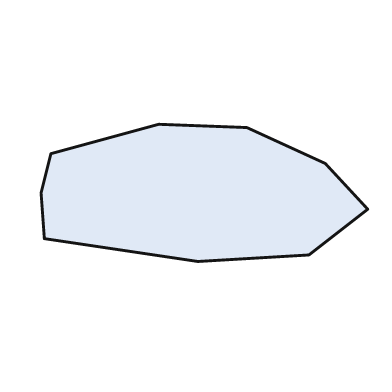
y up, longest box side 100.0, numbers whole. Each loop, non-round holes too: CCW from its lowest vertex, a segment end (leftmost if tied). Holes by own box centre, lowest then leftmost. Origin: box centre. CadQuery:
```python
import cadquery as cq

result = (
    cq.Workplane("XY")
    .moveTo(-2.0, -21.0)
    .lineTo(32.0, -19.0)
    .lineTo(50.0, -5.0)
    .lineTo(37.0, 9.0)
    .lineTo(13.0, 20.0)
    .lineTo(-14.0, 21.0)
    .lineTo(-47.0, 12.0)
    .lineTo(-50.0, 0.0)
    .lineTo(-49.0, -14.0)
    .close()
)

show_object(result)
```